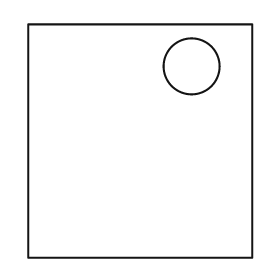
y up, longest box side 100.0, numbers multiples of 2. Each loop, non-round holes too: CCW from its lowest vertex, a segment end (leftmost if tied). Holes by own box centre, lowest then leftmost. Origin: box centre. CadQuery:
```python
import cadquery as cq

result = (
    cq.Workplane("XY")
    .moveTo(-48.0, -50.0)
    .lineTo(48.0, -50.0)
    .lineTo(48.0, 50.0)
    .lineTo(-48.0, 50.0)
    .close()
    .moveTo(22.0, 32.0)
    .circle(12.0)
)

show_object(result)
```